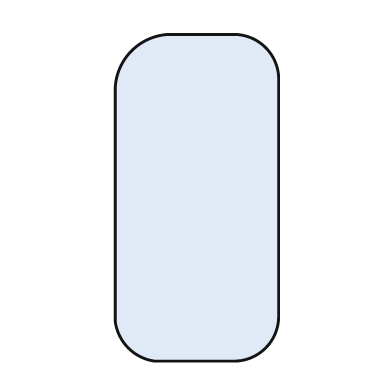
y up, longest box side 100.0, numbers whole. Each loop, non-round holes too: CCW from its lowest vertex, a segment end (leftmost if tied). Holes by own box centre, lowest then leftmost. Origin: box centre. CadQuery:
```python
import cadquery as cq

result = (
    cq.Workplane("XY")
    .moveTo(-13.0, -50.0)
    .lineTo(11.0, -50.0)
    .threePointArc((21.0, -46.0), (25.0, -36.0))
    .lineTo(25.0, 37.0)
    .threePointArc((21.0, 46.0), (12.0, 50.0))
    .lineTo(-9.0, 50.0)
    .threePointArc((-20.0, 45.0), (-25.0, 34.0))
    .lineTo(-25.0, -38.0)
    .threePointArc((-21.0, -46.0), (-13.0, -50.0))
    .close()
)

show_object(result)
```